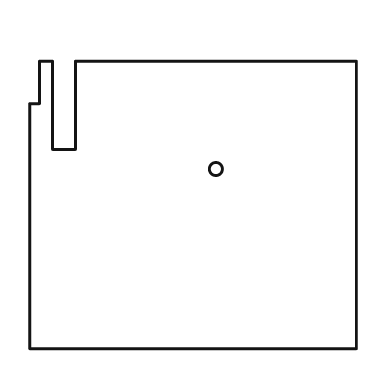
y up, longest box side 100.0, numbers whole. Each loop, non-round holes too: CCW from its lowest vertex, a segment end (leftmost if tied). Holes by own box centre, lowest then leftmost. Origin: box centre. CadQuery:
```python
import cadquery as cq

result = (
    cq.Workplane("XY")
    .moveTo(-50.0, -44.0)
    .lineTo(50.0, -44.0)
    .lineTo(50.0, 44.0)
    .lineTo(-36.0, 44.0)
    .lineTo(-36.0, 17.0)
    .lineTo(-43.0, 17.0)
    .lineTo(-43.0, 44.0)
    .lineTo(-47.0, 44.0)
    .lineTo(-47.0, 31.0)
    .lineTo(-50.0, 31.0)
    .close()
    .moveTo(7.0, 11.0)
    .circle(2.0)
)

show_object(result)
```